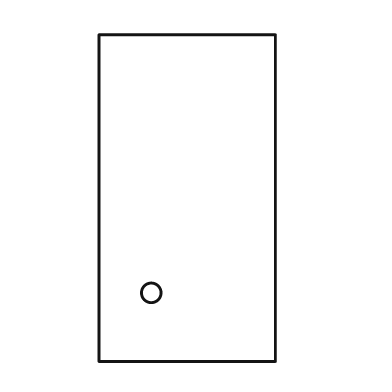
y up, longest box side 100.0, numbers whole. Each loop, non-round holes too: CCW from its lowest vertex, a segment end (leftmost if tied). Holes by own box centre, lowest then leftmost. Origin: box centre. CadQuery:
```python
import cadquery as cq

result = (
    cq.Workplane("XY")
    .moveTo(-27.0, -50.0)
    .lineTo(27.0, -50.0)
    .lineTo(27.0, 50.0)
    .lineTo(-27.0, 50.0)
    .close()
    .moveTo(-11.0, -29.0)
    .circle(3.0)
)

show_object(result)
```